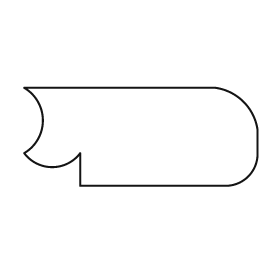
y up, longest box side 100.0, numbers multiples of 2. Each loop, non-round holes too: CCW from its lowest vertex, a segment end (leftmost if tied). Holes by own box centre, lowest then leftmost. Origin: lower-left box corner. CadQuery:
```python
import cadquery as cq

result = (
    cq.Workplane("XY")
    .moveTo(24.0, 0.0)
    .lineTo(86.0, 0.0)
    .threePointArc((96.0, 4.0), (100.0, 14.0))
    .lineTo(100.0, 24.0)
    .threePointArc((94.0, 36.0), (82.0, 42.0))
    .lineTo(0.0, 42.0)
    .threePointArc((8.0, 28.0), (0.0, 14.0))
    .threePointArc((12.0, 8.0), (24.0, 14.0))
    .close()
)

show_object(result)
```